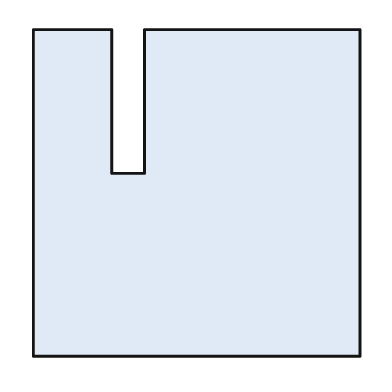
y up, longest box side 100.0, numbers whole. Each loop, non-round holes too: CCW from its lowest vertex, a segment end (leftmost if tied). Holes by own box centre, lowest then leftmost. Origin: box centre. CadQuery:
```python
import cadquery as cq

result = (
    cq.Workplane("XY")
    .moveTo(-50.0, -50.0)
    .lineTo(50.0, -50.0)
    .lineTo(50.0, 50.0)
    .lineTo(-16.0, 50.0)
    .lineTo(-16.0, 6.0)
    .lineTo(-26.0, 6.0)
    .lineTo(-26.0, 50.0)
    .lineTo(-50.0, 50.0)
    .close()
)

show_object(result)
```